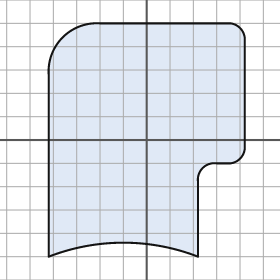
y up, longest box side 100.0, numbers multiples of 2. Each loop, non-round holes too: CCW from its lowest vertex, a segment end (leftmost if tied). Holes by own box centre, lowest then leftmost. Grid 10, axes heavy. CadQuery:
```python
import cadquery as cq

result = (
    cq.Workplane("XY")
    .moveTo(-42.0, -50.0)
    .threePointArc((-10.0, -44.0), (22.0, -50.0))
    .lineTo(22.0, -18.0)
    .threePointArc((24.0, -12.0), (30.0, -10.0))
    .lineTo(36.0, -10.0)
    .threePointArc((40.0, -8.0), (42.0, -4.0))
    .lineTo(42.0, 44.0)
    .threePointArc((40.0, 48.0), (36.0, 50.0))
    .lineTo(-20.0, 50.0)
    .threePointArc((-36.0, 44.0), (-42.0, 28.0))
    .close()
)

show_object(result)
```